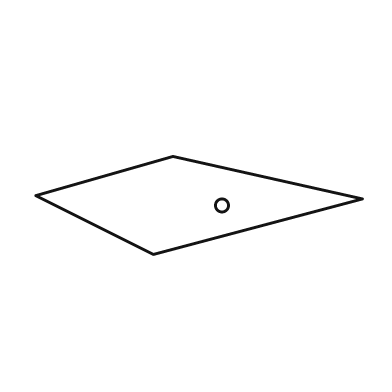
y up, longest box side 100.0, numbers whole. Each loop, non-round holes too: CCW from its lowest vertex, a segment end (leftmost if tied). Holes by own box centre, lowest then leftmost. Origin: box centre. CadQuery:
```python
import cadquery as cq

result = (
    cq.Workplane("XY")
    .moveTo(-14.0, -15.0)
    .lineTo(50.0, 2.0)
    .lineTo(-8.0, 15.0)
    .lineTo(-50.0, 3.0)
    .close()
    .moveTo(7.0, 0.0)
    .circle(2.0)
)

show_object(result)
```